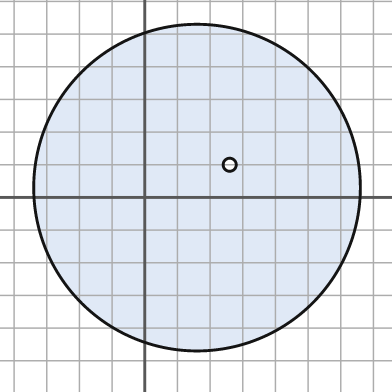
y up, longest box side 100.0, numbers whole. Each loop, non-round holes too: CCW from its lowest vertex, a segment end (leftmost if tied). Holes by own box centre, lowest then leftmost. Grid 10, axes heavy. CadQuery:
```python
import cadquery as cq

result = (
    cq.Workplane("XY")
    .moveTo(16.0, 3.0)
    .circle(50.0)
    .moveTo(26.0, 10.0)
    .circle(2.0)
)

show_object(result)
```